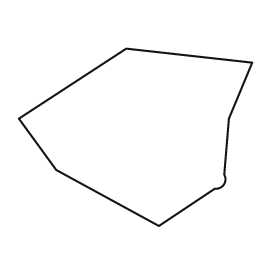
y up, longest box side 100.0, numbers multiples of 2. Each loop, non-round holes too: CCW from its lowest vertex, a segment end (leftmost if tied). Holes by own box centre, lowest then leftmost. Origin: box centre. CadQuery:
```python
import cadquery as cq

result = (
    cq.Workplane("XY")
    .moveTo(10.0, -38.0)
    .lineTo(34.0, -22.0)
    .threePointArc((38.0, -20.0), (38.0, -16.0))
    .lineTo(40.0, 8.0)
    .lineTo(50.0, 32.0)
    .lineTo(-4.0, 38.0)
    .lineTo(-50.0, 8.0)
    .lineTo(-34.0, -14.0)
    .close()
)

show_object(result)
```